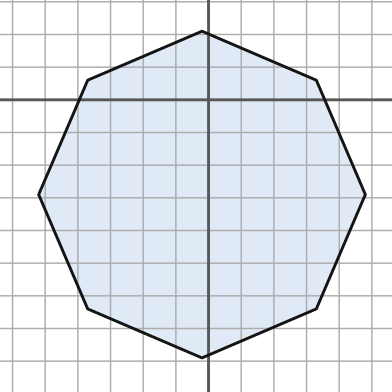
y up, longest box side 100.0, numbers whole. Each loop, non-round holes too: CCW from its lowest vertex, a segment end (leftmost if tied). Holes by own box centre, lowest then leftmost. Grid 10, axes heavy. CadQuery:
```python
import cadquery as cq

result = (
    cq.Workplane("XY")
    .moveTo(-2.0, -79.0)
    .lineTo(33.0, -64.0)
    .lineTo(48.0, -29.0)
    .lineTo(33.0, 6.0)
    .lineTo(-2.0, 21.0)
    .lineTo(-37.0, 6.0)
    .lineTo(-52.0, -29.0)
    .lineTo(-37.0, -64.0)
    .close()
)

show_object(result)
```